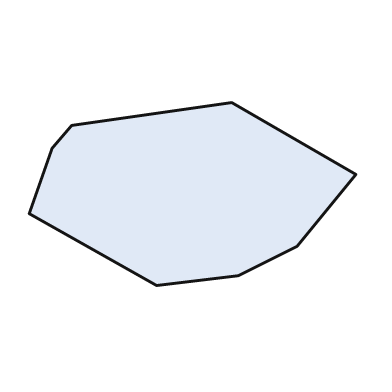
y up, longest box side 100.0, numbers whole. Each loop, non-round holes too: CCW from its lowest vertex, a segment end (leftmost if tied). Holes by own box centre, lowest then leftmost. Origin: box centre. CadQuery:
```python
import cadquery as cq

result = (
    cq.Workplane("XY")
    .moveTo(-11.0, -28.0)
    .lineTo(14.0, -25.0)
    .lineTo(32.0, -16.0)
    .lineTo(50.0, 6.0)
    .lineTo(12.0, 28.0)
    .lineTo(-37.0, 21.0)
    .lineTo(-43.0, 14.0)
    .lineTo(-50.0, -6.0)
    .close()
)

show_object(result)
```